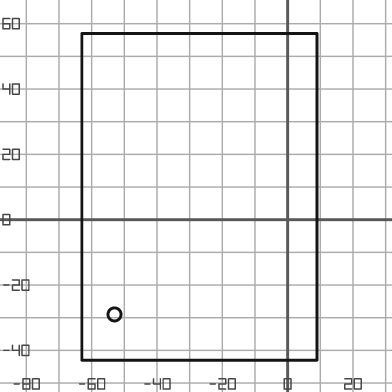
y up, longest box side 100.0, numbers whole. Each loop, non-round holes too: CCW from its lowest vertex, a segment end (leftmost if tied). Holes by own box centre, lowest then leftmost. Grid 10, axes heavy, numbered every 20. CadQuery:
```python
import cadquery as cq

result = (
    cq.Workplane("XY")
    .moveTo(-63.0, -43.0)
    .lineTo(9.0, -43.0)
    .lineTo(9.0, 57.0)
    .lineTo(-63.0, 57.0)
    .close()
    .moveTo(-53.0, -29.0)
    .circle(2.0)
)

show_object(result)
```